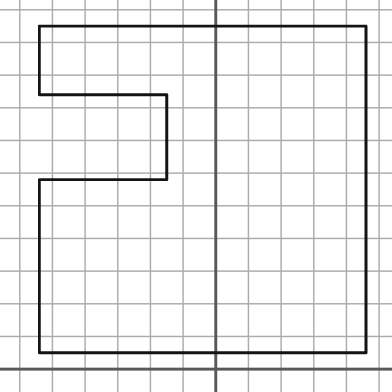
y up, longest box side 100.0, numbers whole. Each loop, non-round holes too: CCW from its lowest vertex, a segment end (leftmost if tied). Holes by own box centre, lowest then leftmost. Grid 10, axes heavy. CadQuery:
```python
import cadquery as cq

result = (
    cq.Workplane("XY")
    .moveTo(-54.0, 5.0)
    .lineTo(46.0, 5.0)
    .lineTo(46.0, 105.0)
    .lineTo(-54.0, 105.0)
    .lineTo(-54.0, 84.0)
    .lineTo(-15.0, 84.0)
    .lineTo(-15.0, 58.0)
    .lineTo(-54.0, 58.0)
    .close()
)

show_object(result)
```